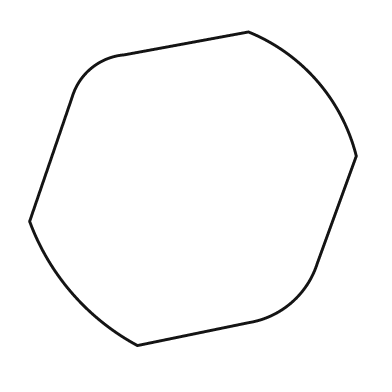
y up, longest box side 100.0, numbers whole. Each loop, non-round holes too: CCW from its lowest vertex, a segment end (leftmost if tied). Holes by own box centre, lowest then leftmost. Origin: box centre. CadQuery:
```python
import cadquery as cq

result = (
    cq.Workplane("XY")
    .moveTo(-17.0, -48.0)
    .lineTo(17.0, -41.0)
    .threePointArc((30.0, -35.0), (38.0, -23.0))
    .lineTo(50.0, 10.0)
    .threePointArc((38.0, 33.0), (17.0, 48.0))
    .lineTo(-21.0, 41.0)
    .threePointArc((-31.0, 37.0), (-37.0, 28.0))
    .lineTo(-50.0, -10.0)
    .threePointArc((-37.0, -32.0), (-17.0, -48.0))
    .close()
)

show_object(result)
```